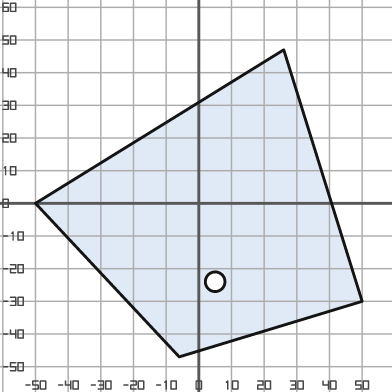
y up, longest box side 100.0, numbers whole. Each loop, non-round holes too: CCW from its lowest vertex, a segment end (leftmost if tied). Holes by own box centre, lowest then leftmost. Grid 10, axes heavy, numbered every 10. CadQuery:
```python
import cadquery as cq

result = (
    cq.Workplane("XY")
    .moveTo(-6.0, -47.0)
    .lineTo(50.0, -30.0)
    .lineTo(26.0, 47.0)
    .lineTo(-50.0, 0.0)
    .close()
    .moveTo(5.0, -24.0)
    .circle(3.0)
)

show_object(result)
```